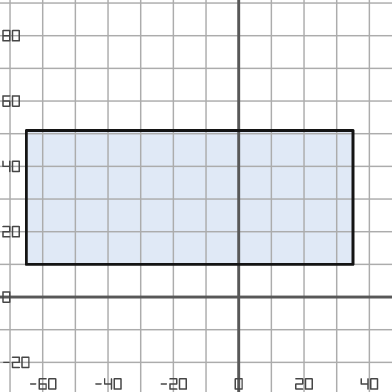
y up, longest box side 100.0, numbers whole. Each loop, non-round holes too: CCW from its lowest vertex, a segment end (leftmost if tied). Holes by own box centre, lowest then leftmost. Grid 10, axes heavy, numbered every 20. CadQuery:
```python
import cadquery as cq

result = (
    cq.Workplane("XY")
    .moveTo(-65.0, 10.0)
    .lineTo(35.0, 10.0)
    .lineTo(35.0, 51.0)
    .lineTo(-65.0, 51.0)
    .close()
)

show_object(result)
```